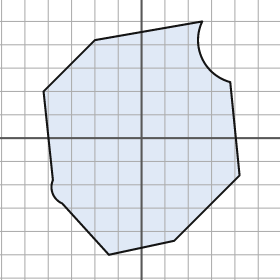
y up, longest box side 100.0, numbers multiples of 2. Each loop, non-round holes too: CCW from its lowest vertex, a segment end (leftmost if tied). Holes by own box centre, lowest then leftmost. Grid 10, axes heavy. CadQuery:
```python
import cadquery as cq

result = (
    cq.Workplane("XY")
    .moveTo(-14.0, -50.0)
    .lineTo(14.0, -44.0)
    .lineTo(42.0, -16.0)
    .lineTo(38.0, 24.0)
    .threePointArc((26.0, 34.0), (26.0, 50.0))
    .lineTo(-20.0, 42.0)
    .lineTo(-42.0, 20.0)
    .lineTo(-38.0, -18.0)
    .threePointArc((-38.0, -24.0), (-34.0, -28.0))
    .close()
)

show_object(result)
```